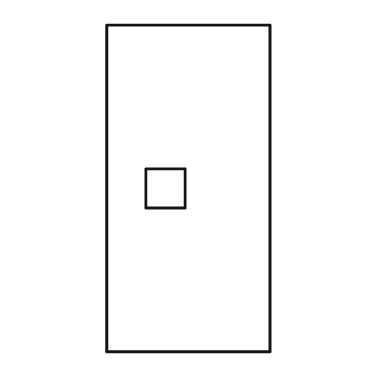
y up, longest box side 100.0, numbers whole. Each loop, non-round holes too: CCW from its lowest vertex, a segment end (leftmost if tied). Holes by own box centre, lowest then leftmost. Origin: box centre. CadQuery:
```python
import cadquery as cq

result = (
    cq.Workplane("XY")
    .moveTo(-25.0, -50.0)
    .lineTo(25.0, -50.0)
    .lineTo(25.0, 50.0)
    .lineTo(-25.0, 50.0)
    .close()
    .moveTo(-13.0, -6.0)
    .lineTo(-1.0, -6.0)
    .lineTo(-1.0, 6.0)
    .lineTo(-13.0, 6.0)
    .close()
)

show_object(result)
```